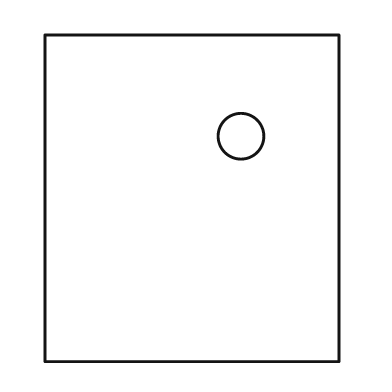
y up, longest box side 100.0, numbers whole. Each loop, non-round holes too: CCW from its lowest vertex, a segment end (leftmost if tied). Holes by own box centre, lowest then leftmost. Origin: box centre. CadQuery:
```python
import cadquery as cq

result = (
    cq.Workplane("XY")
    .moveTo(-45.0, -50.0)
    .lineTo(45.0, -50.0)
    .lineTo(45.0, 50.0)
    .lineTo(-45.0, 50.0)
    .close()
    .moveTo(15.0, 19.0)
    .circle(7.0)
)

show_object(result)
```